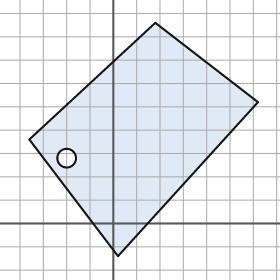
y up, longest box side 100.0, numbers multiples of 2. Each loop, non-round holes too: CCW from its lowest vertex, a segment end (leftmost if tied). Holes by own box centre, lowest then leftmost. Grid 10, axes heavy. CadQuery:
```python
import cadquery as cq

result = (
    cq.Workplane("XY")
    .moveTo(2.0, -14.0)
    .lineTo(62.0, 52.0)
    .lineTo(18.0, 86.0)
    .lineTo(-36.0, 36.0)
    .close()
    .moveTo(-20.0, 28.0)
    .circle(4.0)
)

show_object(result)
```